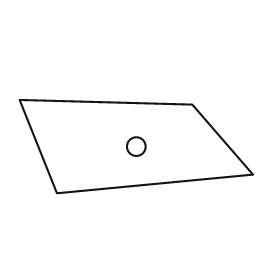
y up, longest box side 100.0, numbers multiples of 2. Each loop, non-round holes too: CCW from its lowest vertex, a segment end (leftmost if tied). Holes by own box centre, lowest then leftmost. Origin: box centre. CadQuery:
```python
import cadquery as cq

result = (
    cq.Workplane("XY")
    .moveTo(-34.0, -20.0)
    .lineTo(50.0, -12.0)
    .lineTo(24.0, 18.0)
    .lineTo(-50.0, 20.0)
    .close()
    .moveTo(0.0, 0.0)
    .circle(4.0)
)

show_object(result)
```